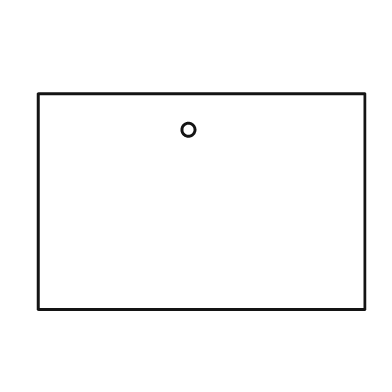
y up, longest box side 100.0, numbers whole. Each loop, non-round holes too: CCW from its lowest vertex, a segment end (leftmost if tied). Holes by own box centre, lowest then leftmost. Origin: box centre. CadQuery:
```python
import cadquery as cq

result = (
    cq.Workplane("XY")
    .moveTo(-50.0, -33.0)
    .lineTo(50.0, -33.0)
    .lineTo(50.0, 33.0)
    .lineTo(-50.0, 33.0)
    .close()
    .moveTo(-4.0, 22.0)
    .circle(2.0)
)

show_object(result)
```